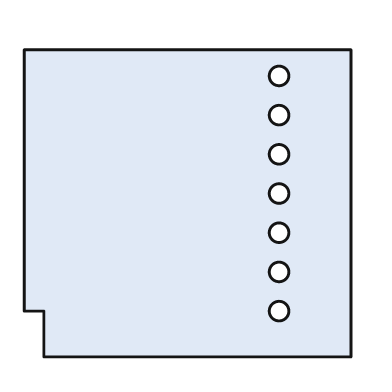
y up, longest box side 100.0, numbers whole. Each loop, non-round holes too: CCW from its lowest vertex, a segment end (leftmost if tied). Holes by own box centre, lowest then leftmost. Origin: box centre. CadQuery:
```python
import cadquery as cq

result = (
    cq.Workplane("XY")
    .moveTo(-44.0, -47.0)
    .lineTo(50.0, -47.0)
    .lineTo(50.0, 47.0)
    .lineTo(-50.0, 47.0)
    .lineTo(-50.0, -33.0)
    .lineTo(-44.0, -33.0)
    .close()
    .moveTo(28.0, -33.0)
    .circle(3.0)
    .moveTo(28.0, -21.0)
    .circle(3.0)
    .moveTo(28.0, -9.0)
    .circle(3.0)
    .moveTo(28.0, 3.0)
    .circle(3.0)
    .moveTo(28.0, 15.0)
    .circle(3.0)
    .moveTo(28.0, 27.0)
    .circle(3.0)
    .moveTo(28.0, 39.0)
    .circle(3.0)
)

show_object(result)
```